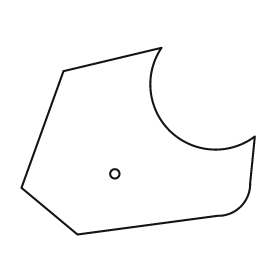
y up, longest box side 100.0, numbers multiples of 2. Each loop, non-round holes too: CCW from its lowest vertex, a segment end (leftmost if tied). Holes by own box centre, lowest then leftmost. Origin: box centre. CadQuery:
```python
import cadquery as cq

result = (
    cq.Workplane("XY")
    .moveTo(-26.0, -40.0)
    .lineTo(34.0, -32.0)
    .threePointArc((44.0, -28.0), (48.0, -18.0))
    .lineTo(50.0, 2.0)
    .threePointArc((14.0, 4.0), (10.0, 40.0))
    .lineTo(-32.0, 30.0)
    .lineTo(-50.0, -20.0)
    .close()
    .moveTo(-10.0, -14.0)
    .circle(2.0)
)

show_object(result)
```